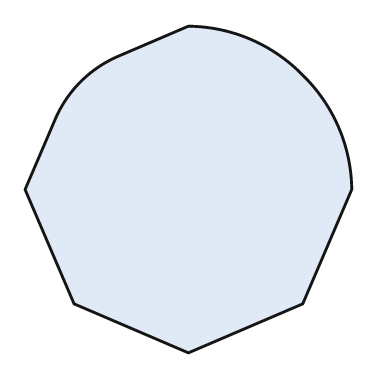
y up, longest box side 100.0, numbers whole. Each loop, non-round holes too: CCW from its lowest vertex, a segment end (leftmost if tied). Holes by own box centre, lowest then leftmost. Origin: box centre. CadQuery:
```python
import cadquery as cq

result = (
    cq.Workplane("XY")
    .moveTo(0.0, -50.0)
    .lineTo(35.0, -35.0)
    .lineTo(50.0, 0.0)
    .threePointArc((46.0, 19.0), (35.0, 35.0))
    .threePointArc((19.0, 46.0), (0.0, 50.0))
    .lineTo(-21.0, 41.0)
    .threePointArc((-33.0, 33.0), (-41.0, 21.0))
    .lineTo(-50.0, 0.0)
    .lineTo(-35.0, -35.0)
    .close()
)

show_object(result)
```